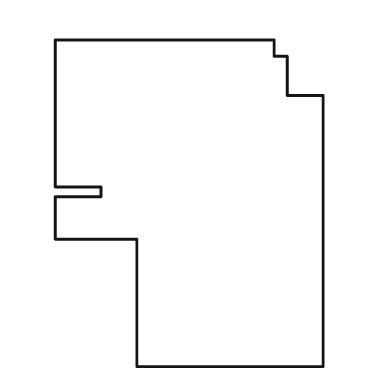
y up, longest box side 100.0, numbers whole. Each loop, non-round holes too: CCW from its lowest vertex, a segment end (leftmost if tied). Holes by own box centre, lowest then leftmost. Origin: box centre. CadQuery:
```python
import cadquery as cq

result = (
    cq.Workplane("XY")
    .moveTo(-16.0, -50.0)
    .lineTo(41.0, -50.0)
    .lineTo(41.0, 33.0)
    .lineTo(30.0, 33.0)
    .lineTo(30.0, 45.0)
    .lineTo(26.0, 45.0)
    .lineTo(26.0, 50.0)
    .lineTo(-41.0, 50.0)
    .lineTo(-41.0, 5.0)
    .lineTo(-27.0, 5.0)
    .lineTo(-27.0, 2.0)
    .lineTo(-41.0, 2.0)
    .lineTo(-41.0, -11.0)
    .lineTo(-16.0, -11.0)
    .close()
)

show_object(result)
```